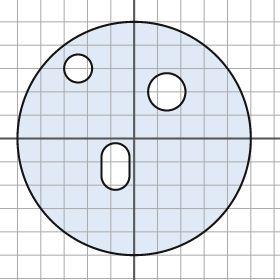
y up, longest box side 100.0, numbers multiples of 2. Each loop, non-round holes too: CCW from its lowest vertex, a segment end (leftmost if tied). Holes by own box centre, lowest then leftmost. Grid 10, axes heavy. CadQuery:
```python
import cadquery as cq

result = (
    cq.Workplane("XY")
    .moveTo(0.0, 0.0)
    .circle(50.0)
    .moveTo(-14.0, -16.0)
    .threePointArc((-8.0, -22.0), (-2.0, -16.0))
    .lineTo(-2.0, -8.0)
    .threePointArc((-8.0, -2.0), (-14.0, -8.0))
    .close()
    .moveTo(14.0, 20.0)
    .circle(8.0)
    .moveTo(-24.0, 30.0)
    .circle(6.0)
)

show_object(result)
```